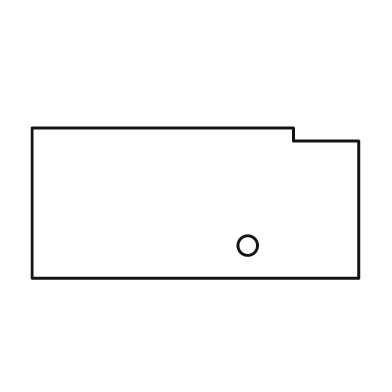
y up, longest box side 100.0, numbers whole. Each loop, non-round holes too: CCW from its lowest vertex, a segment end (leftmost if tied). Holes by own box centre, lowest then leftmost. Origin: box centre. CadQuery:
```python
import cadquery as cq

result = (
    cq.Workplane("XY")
    .moveTo(-50.0, -23.0)
    .lineTo(50.0, -23.0)
    .lineTo(50.0, 19.0)
    .lineTo(30.0, 19.0)
    .lineTo(30.0, 23.0)
    .lineTo(-50.0, 23.0)
    .close()
    .moveTo(16.0, -13.0)
    .circle(3.0)
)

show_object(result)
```